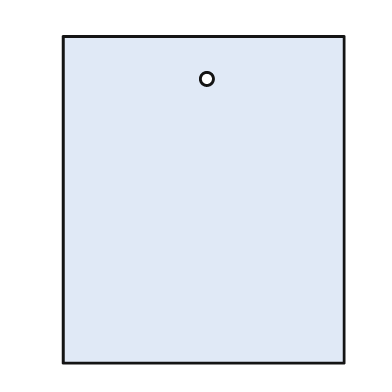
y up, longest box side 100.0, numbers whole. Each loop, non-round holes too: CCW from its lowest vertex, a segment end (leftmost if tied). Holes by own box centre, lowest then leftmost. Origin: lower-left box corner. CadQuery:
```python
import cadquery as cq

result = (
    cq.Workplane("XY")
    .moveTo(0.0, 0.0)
    .lineTo(86.0, 0.0)
    .lineTo(86.0, 100.0)
    .lineTo(0.0, 100.0)
    .close()
    .moveTo(44.0, 87.0)
    .circle(2.0)
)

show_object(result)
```